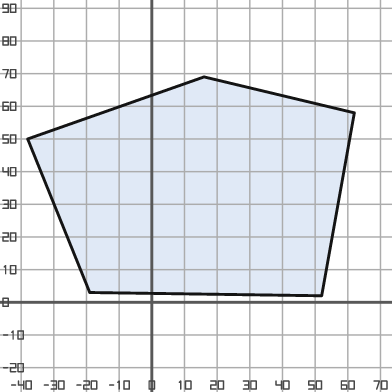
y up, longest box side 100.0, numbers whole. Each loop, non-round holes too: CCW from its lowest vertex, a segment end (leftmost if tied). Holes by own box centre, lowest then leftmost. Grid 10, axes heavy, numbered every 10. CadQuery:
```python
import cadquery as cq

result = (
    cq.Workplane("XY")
    .moveTo(52.0, 2.0)
    .lineTo(62.0, 58.0)
    .lineTo(16.0, 69.0)
    .lineTo(-38.0, 50.0)
    .lineTo(-19.0, 3.0)
    .close()
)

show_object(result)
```